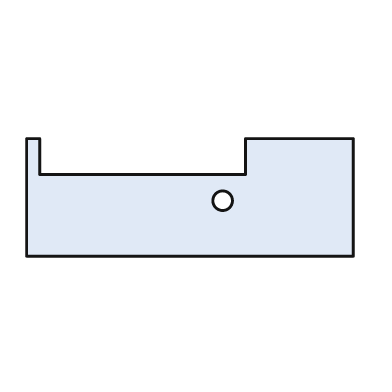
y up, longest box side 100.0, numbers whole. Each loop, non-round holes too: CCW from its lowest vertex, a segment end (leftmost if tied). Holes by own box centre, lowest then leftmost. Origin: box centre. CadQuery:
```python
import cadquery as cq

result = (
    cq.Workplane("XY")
    .moveTo(-50.0, -18.0)
    .lineTo(50.0, -18.0)
    .lineTo(50.0, 18.0)
    .lineTo(17.0, 18.0)
    .lineTo(17.0, 7.0)
    .lineTo(-46.0, 7.0)
    .lineTo(-46.0, 18.0)
    .lineTo(-50.0, 18.0)
    .close()
    .moveTo(10.0, -1.0)
    .circle(3.0)
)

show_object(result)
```